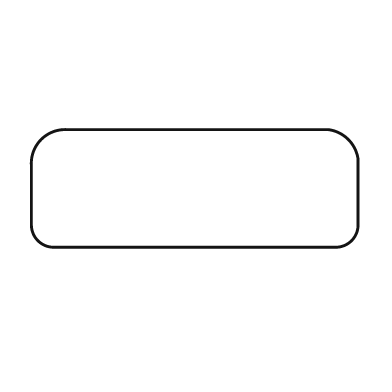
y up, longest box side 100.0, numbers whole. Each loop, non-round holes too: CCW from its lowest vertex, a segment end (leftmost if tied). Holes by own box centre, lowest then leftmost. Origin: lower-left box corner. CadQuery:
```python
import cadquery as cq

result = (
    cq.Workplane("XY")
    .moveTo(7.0, 0.0)
    .lineTo(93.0, 0.0)
    .threePointArc((98.0, 2.0), (100.0, 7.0))
    .lineTo(100.0, 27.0)
    .threePointArc((97.0, 33.0), (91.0, 36.0))
    .lineTo(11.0, 36.0)
    .threePointArc((3.0, 33.0), (0.0, 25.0))
    .lineTo(0.0, 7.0)
    .threePointArc((2.0, 2.0), (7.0, 0.0))
    .close()
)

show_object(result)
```